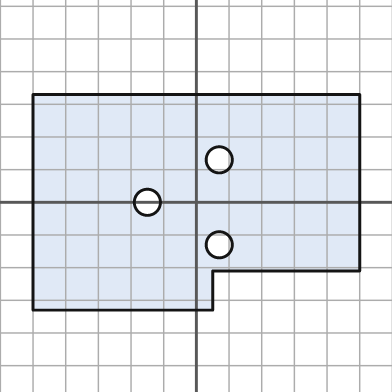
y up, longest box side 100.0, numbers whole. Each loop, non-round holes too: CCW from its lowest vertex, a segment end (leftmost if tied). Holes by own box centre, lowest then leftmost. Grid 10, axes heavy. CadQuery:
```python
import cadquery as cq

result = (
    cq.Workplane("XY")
    .moveTo(-50.0, -33.0)
    .lineTo(5.0, -33.0)
    .lineTo(5.0, -21.0)
    .lineTo(50.0, -21.0)
    .lineTo(50.0, 33.0)
    .lineTo(-50.0, 33.0)
    .close()
    .moveTo(7.0, -13.0)
    .circle(4.0)
    .moveTo(-15.0, 0.0)
    .circle(4.0)
    .moveTo(7.0, 13.0)
    .circle(4.0)
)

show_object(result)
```